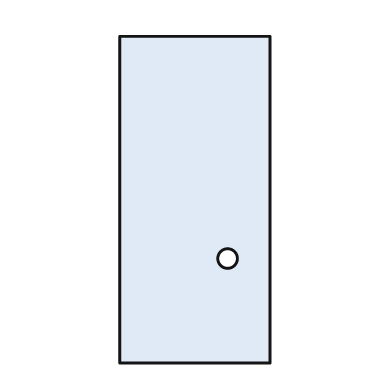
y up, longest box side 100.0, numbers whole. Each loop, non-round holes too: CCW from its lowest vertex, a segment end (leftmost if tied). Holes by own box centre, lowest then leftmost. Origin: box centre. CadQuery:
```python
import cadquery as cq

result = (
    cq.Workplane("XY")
    .moveTo(-23.0, -50.0)
    .lineTo(23.0, -50.0)
    .lineTo(23.0, 50.0)
    .lineTo(-23.0, 50.0)
    .close()
    .moveTo(10.0, -18.0)
    .circle(3.0)
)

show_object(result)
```